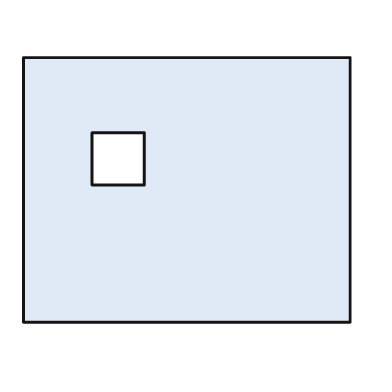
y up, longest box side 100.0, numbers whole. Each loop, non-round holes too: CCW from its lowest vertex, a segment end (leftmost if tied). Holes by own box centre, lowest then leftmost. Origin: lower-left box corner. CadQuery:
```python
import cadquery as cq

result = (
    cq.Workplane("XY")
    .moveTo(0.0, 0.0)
    .lineTo(100.0, 0.0)
    .lineTo(100.0, 81.0)
    .lineTo(0.0, 81.0)
    .close()
    .moveTo(21.0, 42.0)
    .lineTo(37.0, 42.0)
    .lineTo(37.0, 58.0)
    .lineTo(21.0, 58.0)
    .close()
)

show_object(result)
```